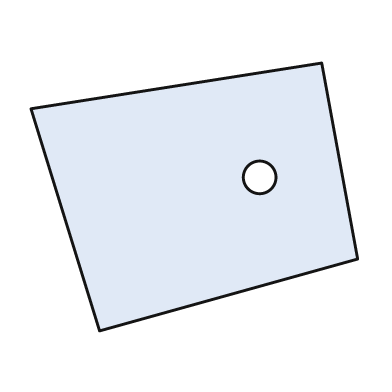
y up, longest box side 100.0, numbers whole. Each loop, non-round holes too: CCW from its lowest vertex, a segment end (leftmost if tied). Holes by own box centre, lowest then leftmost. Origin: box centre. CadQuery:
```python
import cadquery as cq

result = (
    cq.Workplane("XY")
    .moveTo(-29.0, -41.0)
    .lineTo(50.0, -19.0)
    .lineTo(39.0, 41.0)
    .lineTo(-50.0, 27.0)
    .close()
    .moveTo(20.0, 6.0)
    .circle(5.0)
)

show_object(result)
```